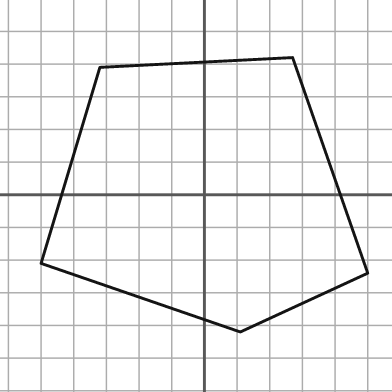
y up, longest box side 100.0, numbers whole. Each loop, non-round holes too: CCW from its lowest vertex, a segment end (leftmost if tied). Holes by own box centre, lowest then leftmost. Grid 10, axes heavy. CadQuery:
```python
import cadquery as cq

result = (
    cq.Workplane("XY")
    .moveTo(11.0, -42.0)
    .lineTo(50.0, -24.0)
    .lineTo(27.0, 42.0)
    .lineTo(-32.0, 39.0)
    .lineTo(-50.0, -21.0)
    .close()
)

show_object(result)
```